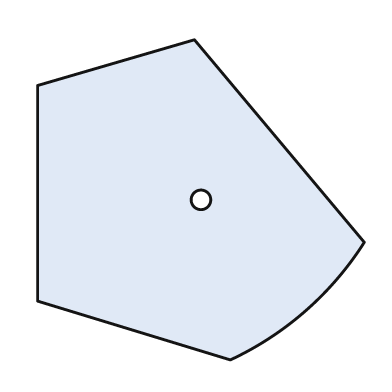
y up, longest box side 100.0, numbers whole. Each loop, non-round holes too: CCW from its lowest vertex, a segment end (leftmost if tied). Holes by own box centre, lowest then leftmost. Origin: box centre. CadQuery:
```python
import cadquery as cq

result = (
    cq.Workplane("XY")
    .moveTo(9.0, -49.0)
    .threePointArc((32.0, -34.0), (50.0, -13.0))
    .lineTo(-2.0, 49.0)
    .lineTo(-50.0, 35.0)
    .lineTo(-50.0, -31.0)
    .close()
    .moveTo(0.0, 0.0)
    .circle(3.0)
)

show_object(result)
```